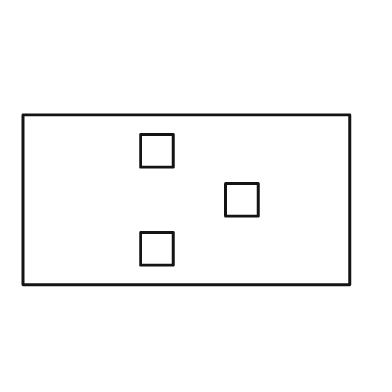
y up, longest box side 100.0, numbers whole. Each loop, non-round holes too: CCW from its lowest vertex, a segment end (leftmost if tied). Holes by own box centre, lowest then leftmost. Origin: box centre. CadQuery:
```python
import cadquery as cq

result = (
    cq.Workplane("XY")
    .moveTo(-50.0, -26.0)
    .lineTo(50.0, -26.0)
    .lineTo(50.0, 26.0)
    .lineTo(-50.0, 26.0)
    .close()
    .moveTo(-14.0, -20.0)
    .lineTo(-4.0, -20.0)
    .lineTo(-4.0, -10.0)
    .lineTo(-14.0, -10.0)
    .close()
    .moveTo(12.0, -5.0)
    .lineTo(22.0, -5.0)
    .lineTo(22.0, 5.0)
    .lineTo(12.0, 5.0)
    .close()
    .moveTo(-14.0, 10.0)
    .lineTo(-4.0, 10.0)
    .lineTo(-4.0, 20.0)
    .lineTo(-14.0, 20.0)
    .close()
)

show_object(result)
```